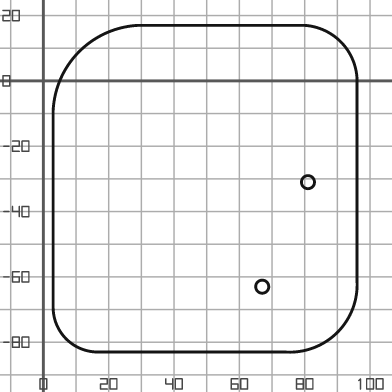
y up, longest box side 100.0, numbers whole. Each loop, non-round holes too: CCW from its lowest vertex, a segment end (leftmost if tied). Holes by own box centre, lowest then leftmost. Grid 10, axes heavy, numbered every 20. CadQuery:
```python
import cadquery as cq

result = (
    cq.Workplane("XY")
    .moveTo(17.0, -83.0)
    .lineTo(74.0, -83.0)
    .threePointArc((90.0, -77.0), (96.0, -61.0))
    .lineTo(96.0, 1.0)
    .threePointArc((91.0, 12.0), (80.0, 17.0))
    .lineTo(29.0, 17.0)
    .threePointArc((11.0, 9.0), (3.0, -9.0))
    .lineTo(3.0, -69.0)
    .threePointArc((7.0, -79.0), (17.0, -83.0))
    .close()
    .moveTo(67.0, -63.0)
    .circle(2.0)
    .moveTo(81.0, -31.0)
    .circle(2.0)
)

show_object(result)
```